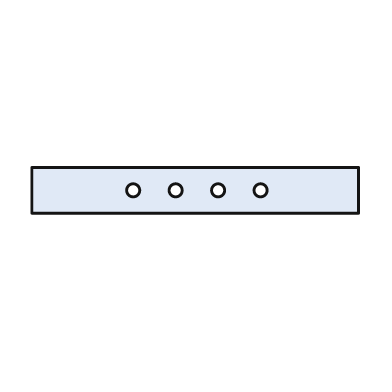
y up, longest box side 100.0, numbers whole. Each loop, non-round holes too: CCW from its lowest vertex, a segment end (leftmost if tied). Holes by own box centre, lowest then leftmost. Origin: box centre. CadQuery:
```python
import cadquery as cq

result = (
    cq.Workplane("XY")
    .moveTo(-50.0, -7.0)
    .lineTo(50.0, -7.0)
    .lineTo(50.0, 7.0)
    .lineTo(-50.0, 7.0)
    .close()
    .moveTo(-19.0, 0.0)
    .circle(2.0)
    .moveTo(-6.0, 0.0)
    .circle(2.0)
    .moveTo(7.0, 0.0)
    .circle(2.0)
    .moveTo(20.0, 0.0)
    .circle(2.0)
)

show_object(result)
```